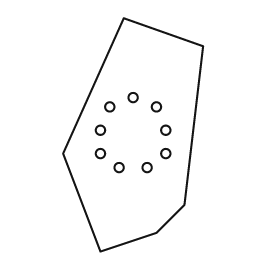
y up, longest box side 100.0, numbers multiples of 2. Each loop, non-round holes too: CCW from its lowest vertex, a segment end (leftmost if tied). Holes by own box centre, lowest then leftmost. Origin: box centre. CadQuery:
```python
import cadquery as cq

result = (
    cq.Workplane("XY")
    .moveTo(-14.0, -50.0)
    .lineTo(10.0, -42.0)
    .lineTo(22.0, -30.0)
    .lineTo(30.0, 38.0)
    .lineTo(-4.0, 50.0)
    .lineTo(-30.0, -8.0)
    .close()
    .moveTo(-6.0, -14.0)
    .circle(2.0)
    .moveTo(6.0, -14.0)
    .circle(2.0)
    .moveTo(-14.0, -8.0)
    .circle(2.0)
    .moveTo(14.0, -8.0)
    .circle(2.0)
    .moveTo(-14.0, 2.0)
    .circle(2.0)
    .moveTo(14.0, 2.0)
    .circle(2.0)
    .moveTo(-10.0, 12.0)
    .circle(2.0)
    .moveTo(10.0, 12.0)
    .circle(2.0)
    .moveTo(0.0, 16.0)
    .circle(2.0)
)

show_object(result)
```